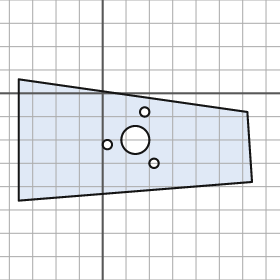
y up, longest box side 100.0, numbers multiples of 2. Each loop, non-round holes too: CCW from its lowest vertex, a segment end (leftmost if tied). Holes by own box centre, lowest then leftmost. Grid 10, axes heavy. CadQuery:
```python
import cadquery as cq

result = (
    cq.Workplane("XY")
    .moveTo(-36.0, -46.0)
    .lineTo(64.0, -38.0)
    .lineTo(62.0, -8.0)
    .lineTo(-36.0, 6.0)
    .close()
    .moveTo(22.0, -30.0)
    .circle(2.0)
    .moveTo(2.0, -22.0)
    .circle(2.0)
    .moveTo(14.0, -20.0)
    .circle(6.0)
    .moveTo(18.0, -8.0)
    .circle(2.0)
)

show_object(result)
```